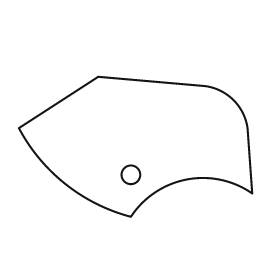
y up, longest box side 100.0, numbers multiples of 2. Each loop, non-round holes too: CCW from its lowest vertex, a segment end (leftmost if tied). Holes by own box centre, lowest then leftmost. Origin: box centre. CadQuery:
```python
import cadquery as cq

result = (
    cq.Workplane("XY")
    .moveTo(-2.0, -30.0)
    .threePointArc((22.0, -14.0), (50.0, -20.0))
    .lineTo(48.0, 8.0)
    .threePointArc((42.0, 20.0), (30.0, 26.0))
    .lineTo(-16.0, 30.0)
    .lineTo(-50.0, 8.0)
    .threePointArc((-30.0, -16.0), (-2.0, -30.0))
    .close()
    .moveTo(-2.0, -12.0)
    .circle(4.0)
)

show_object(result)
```